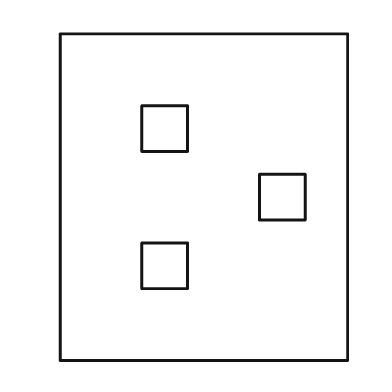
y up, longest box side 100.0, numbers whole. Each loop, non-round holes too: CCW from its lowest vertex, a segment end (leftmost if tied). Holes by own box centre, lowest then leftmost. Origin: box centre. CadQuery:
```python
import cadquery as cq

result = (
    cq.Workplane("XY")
    .moveTo(-44.0, -50.0)
    .lineTo(44.0, -50.0)
    .lineTo(44.0, 50.0)
    .lineTo(-44.0, 50.0)
    .close()
    .moveTo(-19.0, -28.0)
    .lineTo(-5.0, -28.0)
    .lineTo(-5.0, -14.0)
    .lineTo(-19.0, -14.0)
    .close()
    .moveTo(17.0, -7.0)
    .lineTo(31.0, -7.0)
    .lineTo(31.0, 7.0)
    .lineTo(17.0, 7.0)
    .close()
    .moveTo(-19.0, 14.0)
    .lineTo(-5.0, 14.0)
    .lineTo(-5.0, 28.0)
    .lineTo(-19.0, 28.0)
    .close()
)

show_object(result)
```